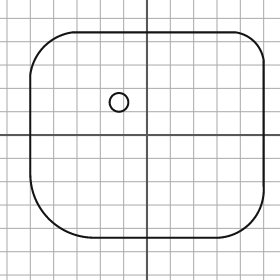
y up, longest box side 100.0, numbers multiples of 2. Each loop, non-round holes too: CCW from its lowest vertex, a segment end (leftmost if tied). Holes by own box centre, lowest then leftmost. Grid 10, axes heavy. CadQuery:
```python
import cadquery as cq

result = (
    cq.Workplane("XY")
    .moveTo(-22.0, -44.0)
    .lineTo(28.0, -44.0)
    .threePointArc((44.0, -38.0), (50.0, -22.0))
    .lineTo(50.0, 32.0)
    .threePointArc((46.0, 40.0), (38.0, 44.0))
    .lineTo(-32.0, 44.0)
    .threePointArc((-44.0, 38.0), (-50.0, 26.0))
    .lineTo(-50.0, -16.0)
    .threePointArc((-42.0, -36.0), (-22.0, -44.0))
    .close()
    .moveTo(-12.0, 14.0)
    .circle(4.0)
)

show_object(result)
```